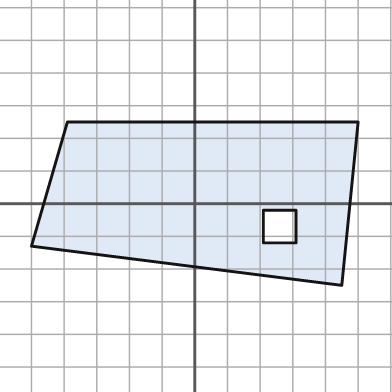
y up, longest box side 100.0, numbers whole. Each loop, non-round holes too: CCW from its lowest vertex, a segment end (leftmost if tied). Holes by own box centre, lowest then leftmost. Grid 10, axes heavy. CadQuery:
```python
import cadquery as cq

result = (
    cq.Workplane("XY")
    .moveTo(45.0, -25.0)
    .lineTo(50.0, 25.0)
    .lineTo(-39.0, 25.0)
    .lineTo(-50.0, -13.0)
    .close()
    .moveTo(21.0, -12.0)
    .lineTo(31.0, -12.0)
    .lineTo(31.0, -2.0)
    .lineTo(21.0, -2.0)
    .close()
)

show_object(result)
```